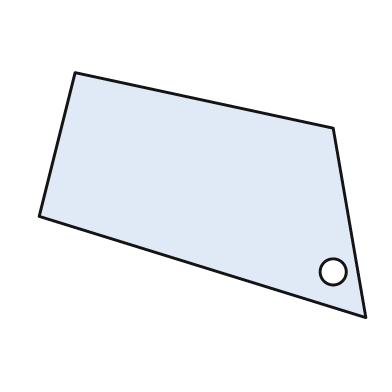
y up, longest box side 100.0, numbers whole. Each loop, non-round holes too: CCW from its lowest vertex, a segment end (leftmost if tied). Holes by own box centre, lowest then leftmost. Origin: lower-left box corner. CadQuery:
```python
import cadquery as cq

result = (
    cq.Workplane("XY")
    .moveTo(100.0, 0.0)
    .lineTo(90.0, 58.0)
    .lineTo(11.0, 75.0)
    .lineTo(0.0, 31.0)
    .close()
    .moveTo(90.0, 14.0)
    .circle(4.0)
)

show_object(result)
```